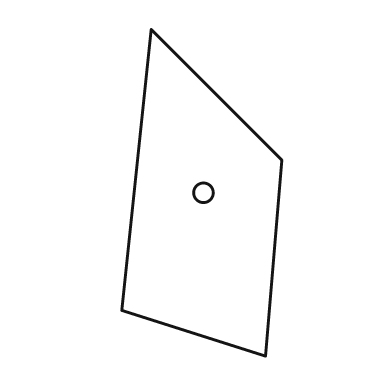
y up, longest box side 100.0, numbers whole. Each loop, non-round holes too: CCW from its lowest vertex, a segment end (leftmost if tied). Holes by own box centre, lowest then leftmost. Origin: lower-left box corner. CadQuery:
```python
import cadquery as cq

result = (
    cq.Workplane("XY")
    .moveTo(44.0, 0.0)
    .lineTo(49.0, 60.0)
    .lineTo(9.0, 100.0)
    .lineTo(0.0, 14.0)
    .close()
    .moveTo(25.0, 50.0)
    .circle(3.0)
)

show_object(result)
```